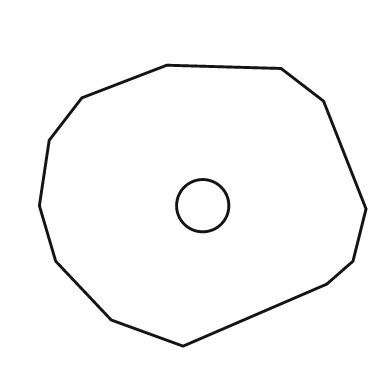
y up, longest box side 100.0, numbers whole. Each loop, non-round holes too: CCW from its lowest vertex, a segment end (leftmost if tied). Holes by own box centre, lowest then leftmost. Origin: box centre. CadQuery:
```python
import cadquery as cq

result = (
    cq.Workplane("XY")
    .moveTo(-6.0, -43.0)
    .lineTo(38.0, -24.0)
    .lineTo(46.0, -17.0)
    .lineTo(50.0, -1.0)
    .lineTo(37.0, 32.0)
    .lineTo(24.0, 42.0)
    .lineTo(-11.0, 43.0)
    .lineTo(-37.0, 33.0)
    .lineTo(-47.0, 20.0)
    .lineTo(-50.0, 0.0)
    .lineTo(-45.0, -17.0)
    .lineTo(-28.0, -35.0)
    .close()
    .moveTo(0.0, 0.0)
    .circle(8.0)
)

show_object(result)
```